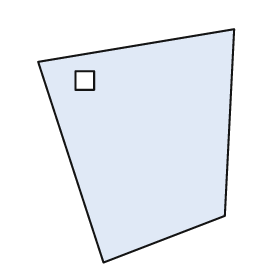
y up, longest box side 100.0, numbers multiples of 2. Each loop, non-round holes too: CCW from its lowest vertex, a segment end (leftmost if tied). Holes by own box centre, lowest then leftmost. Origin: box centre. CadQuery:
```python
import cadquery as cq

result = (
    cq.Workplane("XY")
    .moveTo(-14.0, -50.0)
    .lineTo(38.0, -30.0)
    .lineTo(42.0, 50.0)
    .lineTo(-42.0, 36.0)
    .close()
    .moveTo(-26.0, 24.0)
    .lineTo(-18.0, 24.0)
    .lineTo(-18.0, 32.0)
    .lineTo(-26.0, 32.0)
    .close()
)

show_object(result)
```